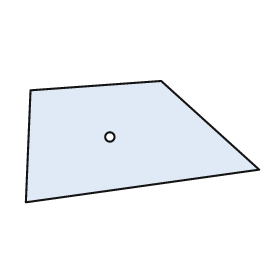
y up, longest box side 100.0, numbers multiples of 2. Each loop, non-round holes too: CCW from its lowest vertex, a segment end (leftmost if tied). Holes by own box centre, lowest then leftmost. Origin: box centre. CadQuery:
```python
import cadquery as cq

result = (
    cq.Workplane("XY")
    .moveTo(-50.0, -26.0)
    .lineTo(50.0, -12.0)
    .lineTo(8.0, 26.0)
    .lineTo(-48.0, 22.0)
    .close()
    .moveTo(-14.0, 2.0)
    .circle(2.0)
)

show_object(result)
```